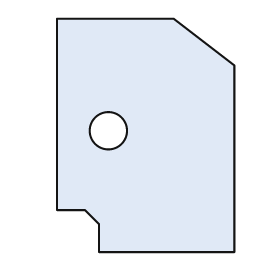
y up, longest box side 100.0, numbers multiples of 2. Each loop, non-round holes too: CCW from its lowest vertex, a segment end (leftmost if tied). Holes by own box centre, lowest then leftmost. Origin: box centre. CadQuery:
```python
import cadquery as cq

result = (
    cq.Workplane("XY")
    .moveTo(-20.0, -50.0)
    .lineTo(38.0, -50.0)
    .lineTo(38.0, 30.0)
    .lineTo(12.0, 50.0)
    .lineTo(-38.0, 50.0)
    .lineTo(-38.0, -32.0)
    .lineTo(-26.0, -32.0)
    .lineTo(-20.0, -38.0)
    .close()
    .moveTo(-16.0, 2.0)
    .circle(8.0)
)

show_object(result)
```